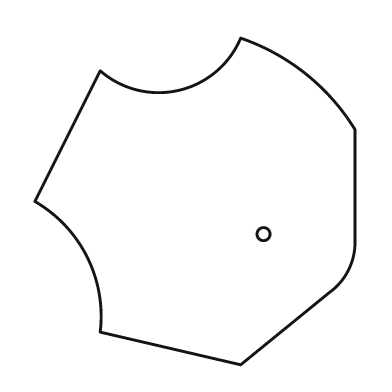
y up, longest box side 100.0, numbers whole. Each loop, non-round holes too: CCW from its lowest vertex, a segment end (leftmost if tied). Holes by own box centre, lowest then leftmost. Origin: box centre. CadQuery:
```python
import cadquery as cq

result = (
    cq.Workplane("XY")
    .moveTo(14.0, -50.0)
    .lineTo(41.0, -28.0)
    .threePointArc((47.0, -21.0), (49.0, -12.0))
    .lineTo(49.0, 22.0)
    .threePointArc((34.0, 39.0), (14.0, 50.0))
    .threePointArc((-5.0, 34.0), (-29.0, 40.0))
    .lineTo(-49.0, 0.0)
    .threePointArc((-33.0, -17.0), (-29.0, -40.0))
    .close()
    .moveTo(21.0, -10.0)
    .circle(2.0)
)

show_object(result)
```